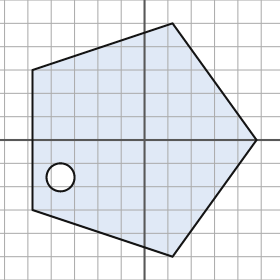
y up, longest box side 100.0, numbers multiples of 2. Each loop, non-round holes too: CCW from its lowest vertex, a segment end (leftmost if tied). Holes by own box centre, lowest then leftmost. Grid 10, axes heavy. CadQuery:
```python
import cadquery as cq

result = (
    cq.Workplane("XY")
    .moveTo(12.0, -50.0)
    .lineTo(48.0, 0.0)
    .lineTo(12.0, 50.0)
    .lineTo(-48.0, 30.0)
    .lineTo(-48.0, -30.0)
    .close()
    .moveTo(-36.0, -16.0)
    .circle(6.0)
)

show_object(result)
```